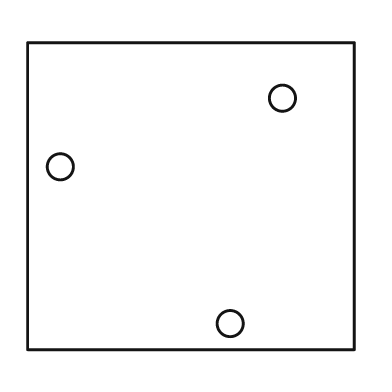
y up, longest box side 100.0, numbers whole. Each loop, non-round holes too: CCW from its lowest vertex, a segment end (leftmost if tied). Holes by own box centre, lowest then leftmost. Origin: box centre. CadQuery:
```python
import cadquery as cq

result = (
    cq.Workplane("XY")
    .moveTo(-50.0, -47.0)
    .lineTo(50.0, -47.0)
    .lineTo(50.0, 47.0)
    .lineTo(-50.0, 47.0)
    .close()
    .moveTo(12.0, -39.0)
    .circle(4.0)
    .moveTo(-40.0, 9.0)
    .circle(4.0)
    .moveTo(28.0, 30.0)
    .circle(4.0)
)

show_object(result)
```